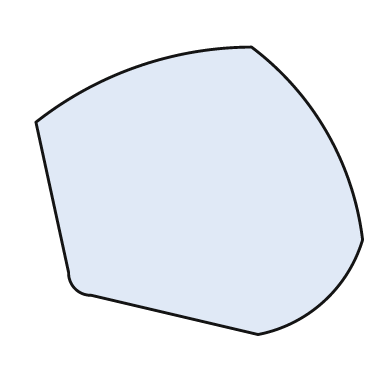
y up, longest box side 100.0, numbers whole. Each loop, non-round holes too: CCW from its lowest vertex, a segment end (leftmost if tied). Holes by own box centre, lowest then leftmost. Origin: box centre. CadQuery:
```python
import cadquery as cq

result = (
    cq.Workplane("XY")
    .moveTo(18.0, -44.0)
    .threePointArc((38.0, -34.0), (50.0, -15.0))
    .threePointArc((39.0, 18.0), (16.0, 44.0))
    .threePointArc((-19.0, 38.0), (-50.0, 21.0))
    .lineTo(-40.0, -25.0)
    .threePointArc((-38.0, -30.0), (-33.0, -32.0))
    .close()
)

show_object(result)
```